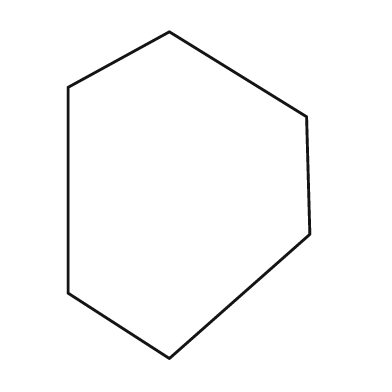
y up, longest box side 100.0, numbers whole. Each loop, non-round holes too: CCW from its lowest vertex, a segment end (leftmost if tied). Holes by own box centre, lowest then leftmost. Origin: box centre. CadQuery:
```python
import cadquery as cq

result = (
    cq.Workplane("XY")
    .moveTo(-6.0, -50.0)
    .lineTo(37.0, -12.0)
    .lineTo(36.0, 24.0)
    .lineTo(-6.0, 50.0)
    .lineTo(-37.0, 33.0)
    .lineTo(-37.0, -30.0)
    .close()
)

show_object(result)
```